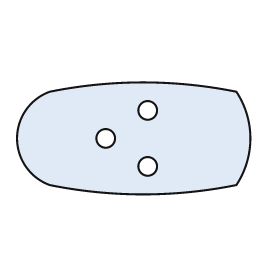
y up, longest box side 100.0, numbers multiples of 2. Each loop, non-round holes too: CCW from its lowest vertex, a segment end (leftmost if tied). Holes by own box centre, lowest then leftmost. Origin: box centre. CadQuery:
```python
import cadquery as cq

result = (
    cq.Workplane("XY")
    .moveTo(-36.0, -20.0)
    .threePointArc((4.0, -24.0), (44.0, -20.0))
    .threePointArc((50.0, 0.0), (44.0, 20.0))
    .threePointArc((4.0, 24.0), (-36.0, 20.0))
    .threePointArc((-50.0, 0.0), (-36.0, -20.0))
    .close()
    .moveTo(6.0, -12.0)
    .circle(4.0)
    .moveTo(-12.0, 0.0)
    .circle(4.0)
    .moveTo(6.0, 12.0)
    .circle(4.0)
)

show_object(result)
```